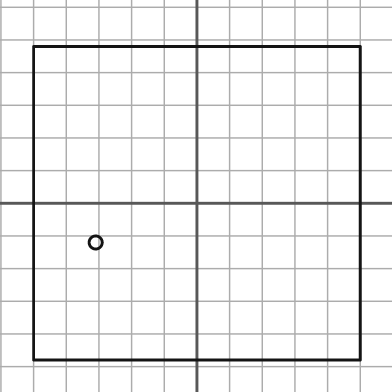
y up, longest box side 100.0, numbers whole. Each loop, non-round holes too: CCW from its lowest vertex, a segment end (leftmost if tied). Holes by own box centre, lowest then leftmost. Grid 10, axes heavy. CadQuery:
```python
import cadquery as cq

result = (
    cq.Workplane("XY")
    .moveTo(-50.0, -48.0)
    .lineTo(50.0, -48.0)
    .lineTo(50.0, 48.0)
    .lineTo(-50.0, 48.0)
    .close()
    .moveTo(-31.0, -12.0)
    .circle(2.0)
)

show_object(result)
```